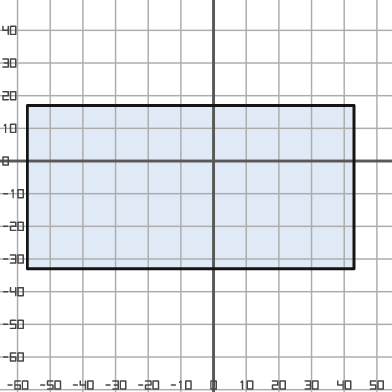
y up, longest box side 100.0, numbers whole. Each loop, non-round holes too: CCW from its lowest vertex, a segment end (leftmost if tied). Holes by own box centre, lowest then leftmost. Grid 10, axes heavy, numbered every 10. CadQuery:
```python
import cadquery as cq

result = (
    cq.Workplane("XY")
    .moveTo(-57.0, -33.0)
    .lineTo(43.0, -33.0)
    .lineTo(43.0, 17.0)
    .lineTo(-57.0, 17.0)
    .close()
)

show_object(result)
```